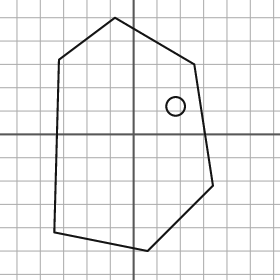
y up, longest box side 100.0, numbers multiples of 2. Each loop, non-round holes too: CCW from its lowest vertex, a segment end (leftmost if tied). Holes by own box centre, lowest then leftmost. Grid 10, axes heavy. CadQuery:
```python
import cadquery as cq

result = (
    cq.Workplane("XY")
    .moveTo(6.0, -50.0)
    .lineTo(34.0, -22.0)
    .lineTo(26.0, 30.0)
    .lineTo(-8.0, 50.0)
    .lineTo(-32.0, 32.0)
    .lineTo(-34.0, -42.0)
    .close()
    .moveTo(18.0, 12.0)
    .circle(4.0)
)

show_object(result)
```